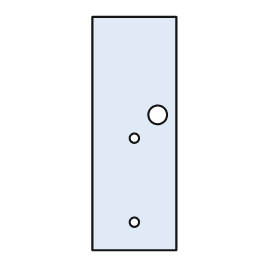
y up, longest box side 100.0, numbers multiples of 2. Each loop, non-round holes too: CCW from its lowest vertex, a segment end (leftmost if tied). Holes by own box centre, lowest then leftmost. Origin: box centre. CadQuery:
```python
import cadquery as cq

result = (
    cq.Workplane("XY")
    .moveTo(-18.0, -50.0)
    .lineTo(18.0, -50.0)
    .lineTo(18.0, 50.0)
    .lineTo(-18.0, 50.0)
    .close()
    .moveTo(0.0, -38.0)
    .circle(2.0)
    .moveTo(0.0, -2.0)
    .circle(2.0)
    .moveTo(10.0, 8.0)
    .circle(4.0)
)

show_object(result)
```